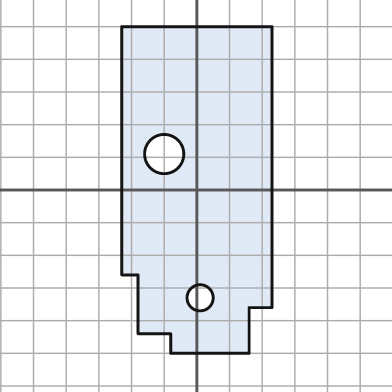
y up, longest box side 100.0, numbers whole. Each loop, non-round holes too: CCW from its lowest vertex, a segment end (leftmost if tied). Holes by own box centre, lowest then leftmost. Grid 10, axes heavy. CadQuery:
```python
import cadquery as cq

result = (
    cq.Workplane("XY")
    .moveTo(-8.0, -50.0)
    .lineTo(16.0, -50.0)
    .lineTo(16.0, -36.0)
    .lineTo(23.0, -36.0)
    .lineTo(23.0, 50.0)
    .lineTo(-23.0, 50.0)
    .lineTo(-23.0, -26.0)
    .lineTo(-18.0, -26.0)
    .lineTo(-18.0, -44.0)
    .lineTo(-8.0, -44.0)
    .close()
    .moveTo(1.0, -33.0)
    .circle(4.0)
    .moveTo(-10.0, 11.0)
    .circle(6.0)
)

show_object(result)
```